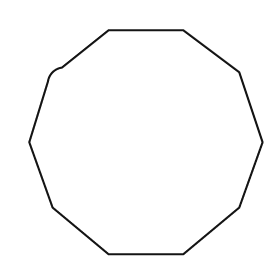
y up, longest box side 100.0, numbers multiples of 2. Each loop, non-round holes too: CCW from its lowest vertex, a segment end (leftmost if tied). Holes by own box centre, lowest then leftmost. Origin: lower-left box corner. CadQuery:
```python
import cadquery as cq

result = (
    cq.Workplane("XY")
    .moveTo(34.0, 0.0)
    .lineTo(66.0, 0.0)
    .lineTo(90.0, 20.0)
    .lineTo(100.0, 48.0)
    .lineTo(90.0, 78.0)
    .lineTo(66.0, 96.0)
    .lineTo(34.0, 96.0)
    .lineTo(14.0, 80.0)
    .threePointArc((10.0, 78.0), (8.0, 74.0))
    .lineTo(0.0, 48.0)
    .lineTo(10.0, 20.0)
    .close()
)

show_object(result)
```